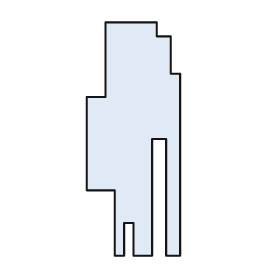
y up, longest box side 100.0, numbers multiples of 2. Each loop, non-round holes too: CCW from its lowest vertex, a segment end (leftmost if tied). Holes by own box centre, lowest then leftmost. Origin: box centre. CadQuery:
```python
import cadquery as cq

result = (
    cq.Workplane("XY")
    .moveTo(-8.0, -50.0)
    .lineTo(-4.0, -50.0)
    .lineTo(-4.0, -36.0)
    .lineTo(0.0, -36.0)
    .lineTo(0.0, -50.0)
    .lineTo(8.0, -50.0)
    .lineTo(8.0, 0.0)
    .lineTo(14.0, 0.0)
    .lineTo(14.0, -50.0)
    .lineTo(20.0, -50.0)
    .lineTo(20.0, 28.0)
    .lineTo(16.0, 28.0)
    .lineTo(16.0, 44.0)
    .lineTo(10.0, 44.0)
    .lineTo(10.0, 50.0)
    .lineTo(-12.0, 50.0)
    .lineTo(-12.0, 18.0)
    .lineTo(-20.0, 18.0)
    .lineTo(-20.0, -22.0)
    .lineTo(-8.0, -22.0)
    .close()
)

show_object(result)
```